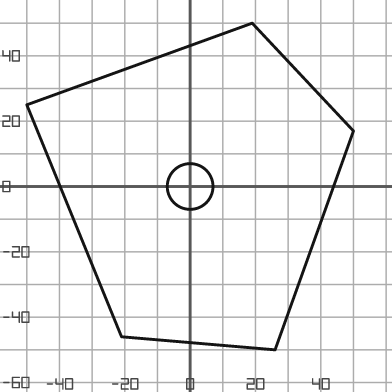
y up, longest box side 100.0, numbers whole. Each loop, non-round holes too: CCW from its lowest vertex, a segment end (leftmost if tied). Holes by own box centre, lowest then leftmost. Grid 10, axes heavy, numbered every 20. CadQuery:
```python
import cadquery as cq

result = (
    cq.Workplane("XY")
    .moveTo(26.0, -50.0)
    .lineTo(50.0, 17.0)
    .lineTo(19.0, 50.0)
    .lineTo(-50.0, 25.0)
    .lineTo(-21.0, -46.0)
    .close()
    .moveTo(0.0, 0.0)
    .circle(7.0)
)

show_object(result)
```